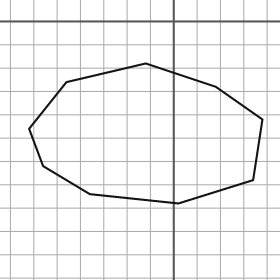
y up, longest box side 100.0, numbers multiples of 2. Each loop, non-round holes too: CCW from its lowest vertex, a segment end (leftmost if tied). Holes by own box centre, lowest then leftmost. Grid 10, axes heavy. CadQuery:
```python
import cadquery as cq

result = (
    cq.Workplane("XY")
    .moveTo(2.0, -78.0)
    .lineTo(34.0, -68.0)
    .lineTo(38.0, -42.0)
    .lineTo(18.0, -28.0)
    .lineTo(-12.0, -18.0)
    .lineTo(-46.0, -26.0)
    .lineTo(-62.0, -46.0)
    .lineTo(-56.0, -62.0)
    .lineTo(-36.0, -74.0)
    .close()
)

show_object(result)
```